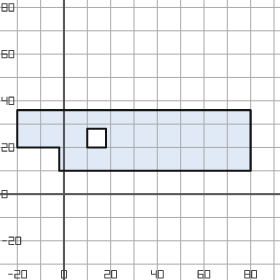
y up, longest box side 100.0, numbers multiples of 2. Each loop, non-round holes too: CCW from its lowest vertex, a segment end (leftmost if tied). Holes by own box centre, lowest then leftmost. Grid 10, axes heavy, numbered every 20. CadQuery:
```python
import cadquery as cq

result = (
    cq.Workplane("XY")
    .moveTo(-2.0, 10.0)
    .lineTo(80.0, 10.0)
    .lineTo(80.0, 36.0)
    .lineTo(-20.0, 36.0)
    .lineTo(-20.0, 20.0)
    .lineTo(-2.0, 20.0)
    .close()
    .moveTo(10.0, 20.0)
    .lineTo(18.0, 20.0)
    .lineTo(18.0, 28.0)
    .lineTo(10.0, 28.0)
    .close()
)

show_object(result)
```